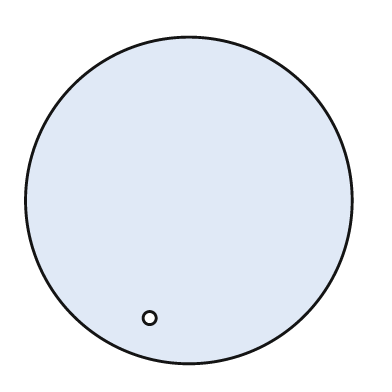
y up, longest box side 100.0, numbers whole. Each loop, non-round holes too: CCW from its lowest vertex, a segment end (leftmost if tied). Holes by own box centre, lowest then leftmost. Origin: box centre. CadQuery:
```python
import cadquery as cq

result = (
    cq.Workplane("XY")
    .moveTo(0.0, 0.0)
    .circle(50.0)
    .moveTo(-12.0, -36.0)
    .circle(2.0)
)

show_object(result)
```